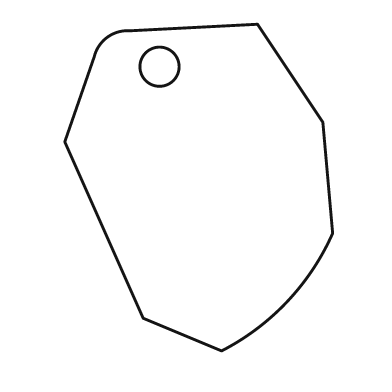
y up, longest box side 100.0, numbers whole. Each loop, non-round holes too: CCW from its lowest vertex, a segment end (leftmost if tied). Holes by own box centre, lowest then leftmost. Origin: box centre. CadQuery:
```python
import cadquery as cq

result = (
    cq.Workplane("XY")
    .moveTo(7.0, -50.0)
    .threePointArc((27.0, -35.0), (41.0, -14.0))
    .lineTo(38.0, 20.0)
    .lineTo(18.0, 50.0)
    .lineTo(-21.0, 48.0)
    .threePointArc((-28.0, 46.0), (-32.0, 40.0))
    .lineTo(-41.0, 14.0)
    .lineTo(-17.0, -40.0)
    .close()
    .moveTo(-12.0, 37.0)
    .circle(6.0)
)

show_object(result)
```